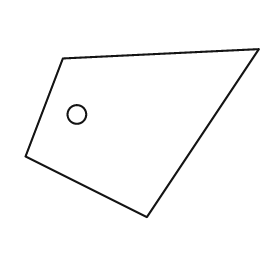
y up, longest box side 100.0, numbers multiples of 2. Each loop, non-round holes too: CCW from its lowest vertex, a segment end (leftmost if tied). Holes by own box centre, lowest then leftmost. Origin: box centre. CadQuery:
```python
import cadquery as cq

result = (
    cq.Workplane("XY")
    .moveTo(2.0, -36.0)
    .lineTo(50.0, 36.0)
    .lineTo(-34.0, 32.0)
    .lineTo(-50.0, -10.0)
    .close()
    .moveTo(-28.0, 8.0)
    .circle(4.0)
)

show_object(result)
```